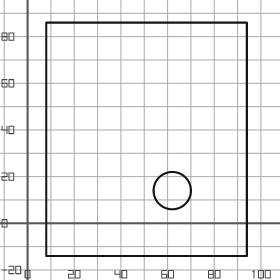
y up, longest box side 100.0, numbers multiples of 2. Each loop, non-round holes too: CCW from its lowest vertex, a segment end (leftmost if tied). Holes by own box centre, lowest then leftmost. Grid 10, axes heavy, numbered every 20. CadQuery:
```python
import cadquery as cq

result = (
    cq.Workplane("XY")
    .moveTo(8.0, -14.0)
    .lineTo(94.0, -14.0)
    .lineTo(94.0, 86.0)
    .lineTo(8.0, 86.0)
    .close()
    .moveTo(62.0, 14.0)
    .circle(8.0)
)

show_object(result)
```